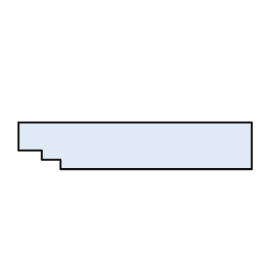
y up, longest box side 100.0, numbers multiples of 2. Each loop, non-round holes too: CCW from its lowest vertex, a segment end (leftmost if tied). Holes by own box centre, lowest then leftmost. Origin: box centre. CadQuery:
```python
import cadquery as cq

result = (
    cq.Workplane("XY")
    .moveTo(-32.0, -10.0)
    .lineTo(50.0, -10.0)
    .lineTo(50.0, 10.0)
    .lineTo(-50.0, 10.0)
    .lineTo(-50.0, -2.0)
    .lineTo(-40.0, -2.0)
    .lineTo(-40.0, -6.0)
    .lineTo(-32.0, -6.0)
    .close()
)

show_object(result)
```